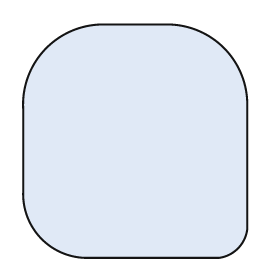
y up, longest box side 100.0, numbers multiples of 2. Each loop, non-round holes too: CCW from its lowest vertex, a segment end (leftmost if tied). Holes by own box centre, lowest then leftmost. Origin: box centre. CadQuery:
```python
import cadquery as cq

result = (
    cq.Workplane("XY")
    .moveTo(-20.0, -50.0)
    .lineTo(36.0, -50.0)
    .threePointArc((44.0, -46.0), (48.0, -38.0))
    .lineTo(48.0, 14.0)
    .threePointArc((38.0, 40.0), (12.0, 50.0))
    .lineTo(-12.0, 50.0)
    .threePointArc((-38.0, 40.0), (-48.0, 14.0))
    .lineTo(-48.0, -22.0)
    .threePointArc((-40.0, -42.0), (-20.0, -50.0))
    .close()
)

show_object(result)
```